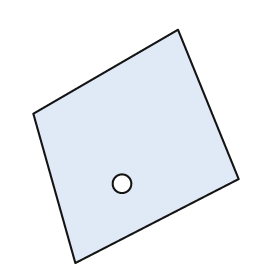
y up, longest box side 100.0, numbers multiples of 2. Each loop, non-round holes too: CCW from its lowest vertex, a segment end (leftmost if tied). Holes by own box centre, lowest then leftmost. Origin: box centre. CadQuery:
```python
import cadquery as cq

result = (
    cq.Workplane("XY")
    .moveTo(-26.0, -50.0)
    .lineTo(44.0, -14.0)
    .lineTo(18.0, 50.0)
    .lineTo(-44.0, 14.0)
    .close()
    .moveTo(-6.0, -16.0)
    .circle(4.0)
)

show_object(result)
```